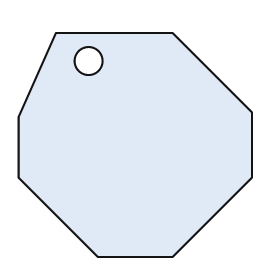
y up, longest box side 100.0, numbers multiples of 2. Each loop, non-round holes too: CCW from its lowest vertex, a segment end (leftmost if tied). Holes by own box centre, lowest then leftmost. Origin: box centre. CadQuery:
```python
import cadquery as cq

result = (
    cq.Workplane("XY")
    .moveTo(-16.0, -48.0)
    .lineTo(16.0, -48.0)
    .lineTo(50.0, -14.0)
    .lineTo(50.0, 14.0)
    .lineTo(16.0, 48.0)
    .lineTo(-34.0, 48.0)
    .lineTo(-50.0, 12.0)
    .lineTo(-50.0, -14.0)
    .close()
    .moveTo(-20.0, 36.0)
    .circle(6.0)
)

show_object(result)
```